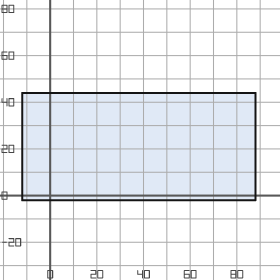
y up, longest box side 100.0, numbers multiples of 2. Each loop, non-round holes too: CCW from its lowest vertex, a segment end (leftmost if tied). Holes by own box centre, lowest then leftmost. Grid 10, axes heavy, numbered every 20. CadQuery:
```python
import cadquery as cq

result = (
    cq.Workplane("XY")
    .moveTo(-12.0, -2.0)
    .lineTo(88.0, -2.0)
    .lineTo(88.0, 44.0)
    .lineTo(-12.0, 44.0)
    .close()
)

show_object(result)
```